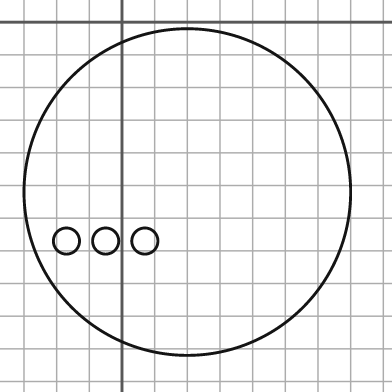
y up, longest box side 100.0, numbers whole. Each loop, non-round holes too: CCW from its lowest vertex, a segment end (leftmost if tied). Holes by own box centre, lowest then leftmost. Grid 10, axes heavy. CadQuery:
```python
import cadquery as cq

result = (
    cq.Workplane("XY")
    .moveTo(20.0, -52.0)
    .circle(50.0)
    .moveTo(-17.0, -67.0)
    .circle(4.0)
    .moveTo(-5.0, -67.0)
    .circle(4.0)
    .moveTo(7.0, -67.0)
    .circle(4.0)
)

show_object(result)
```